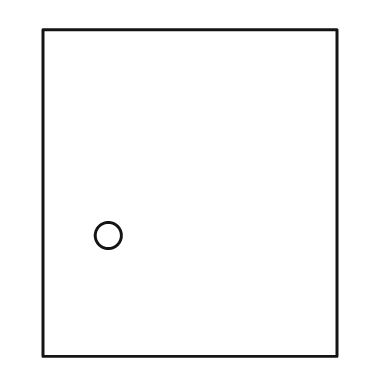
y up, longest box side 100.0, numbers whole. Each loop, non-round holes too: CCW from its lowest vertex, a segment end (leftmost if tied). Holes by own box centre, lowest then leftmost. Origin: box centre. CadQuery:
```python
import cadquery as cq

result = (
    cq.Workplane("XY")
    .moveTo(-45.0, -50.0)
    .lineTo(45.0, -50.0)
    .lineTo(45.0, 50.0)
    .lineTo(-45.0, 50.0)
    .close()
    .moveTo(-25.0, -13.0)
    .circle(4.0)
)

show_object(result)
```